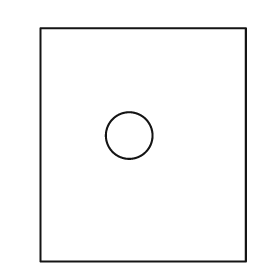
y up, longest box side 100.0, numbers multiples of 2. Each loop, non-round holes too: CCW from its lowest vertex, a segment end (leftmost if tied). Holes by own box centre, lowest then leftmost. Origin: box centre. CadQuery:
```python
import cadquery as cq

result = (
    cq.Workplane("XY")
    .moveTo(-44.0, -50.0)
    .lineTo(44.0, -50.0)
    .lineTo(44.0, 50.0)
    .lineTo(-44.0, 50.0)
    .close()
    .moveTo(-6.0, 4.0)
    .circle(10.0)
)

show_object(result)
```